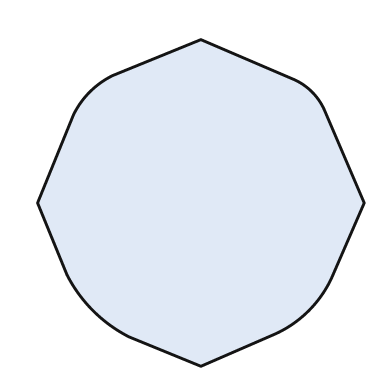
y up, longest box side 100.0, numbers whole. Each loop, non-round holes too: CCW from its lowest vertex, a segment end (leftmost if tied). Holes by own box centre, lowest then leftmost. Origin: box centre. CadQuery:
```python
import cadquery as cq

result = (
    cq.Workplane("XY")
    .moveTo(0.0, -50.0)
    .lineTo(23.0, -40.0)
    .threePointArc((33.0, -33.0), (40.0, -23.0))
    .lineTo(50.0, 0.0)
    .lineTo(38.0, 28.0)
    .threePointArc((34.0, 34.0), (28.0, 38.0))
    .lineTo(0.0, 50.0)
    .lineTo(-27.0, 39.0)
    .threePointArc((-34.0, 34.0), (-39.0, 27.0))
    .lineTo(-50.0, 0.0)
    .lineTo(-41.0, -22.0)
    .threePointArc((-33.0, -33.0), (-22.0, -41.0))
    .close()
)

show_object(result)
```